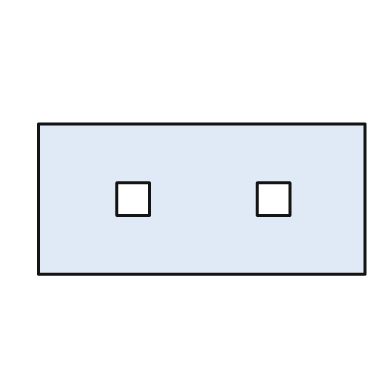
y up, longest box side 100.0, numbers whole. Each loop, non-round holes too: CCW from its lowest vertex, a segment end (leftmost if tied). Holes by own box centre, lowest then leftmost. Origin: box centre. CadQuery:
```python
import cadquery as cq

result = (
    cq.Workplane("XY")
    .moveTo(-50.0, -23.0)
    .lineTo(50.0, -23.0)
    .lineTo(50.0, 23.0)
    .lineTo(-50.0, 23.0)
    .close()
    .moveTo(-26.0, -5.0)
    .lineTo(-16.0, -5.0)
    .lineTo(-16.0, 5.0)
    .lineTo(-26.0, 5.0)
    .close()
    .moveTo(17.0, -5.0)
    .lineTo(27.0, -5.0)
    .lineTo(27.0, 5.0)
    .lineTo(17.0, 5.0)
    .close()
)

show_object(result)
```